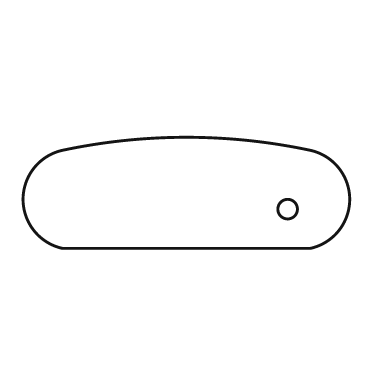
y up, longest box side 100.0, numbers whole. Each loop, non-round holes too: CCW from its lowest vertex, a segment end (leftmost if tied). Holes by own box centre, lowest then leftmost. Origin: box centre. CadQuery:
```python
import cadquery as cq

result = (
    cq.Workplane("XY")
    .moveTo(-38.0, -17.0)
    .lineTo(38.0, -17.0)
    .threePointArc((50.0, -2.0), (38.0, 13.0))
    .threePointArc((0.0, 17.0), (-38.0, 13.0))
    .threePointArc((-50.0, -2.0), (-38.0, -17.0))
    .close()
    .moveTo(31.0, -5.0)
    .circle(3.0)
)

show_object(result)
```